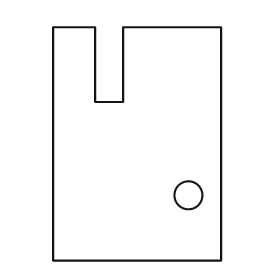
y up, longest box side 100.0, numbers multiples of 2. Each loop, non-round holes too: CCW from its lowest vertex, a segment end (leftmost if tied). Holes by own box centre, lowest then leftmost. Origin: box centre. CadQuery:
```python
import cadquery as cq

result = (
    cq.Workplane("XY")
    .moveTo(-36.0, -50.0)
    .lineTo(36.0, -50.0)
    .lineTo(36.0, 50.0)
    .lineTo(-6.0, 50.0)
    .lineTo(-6.0, 18.0)
    .lineTo(-18.0, 18.0)
    .lineTo(-18.0, 50.0)
    .lineTo(-36.0, 50.0)
    .close()
    .moveTo(22.0, -22.0)
    .circle(6.0)
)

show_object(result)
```